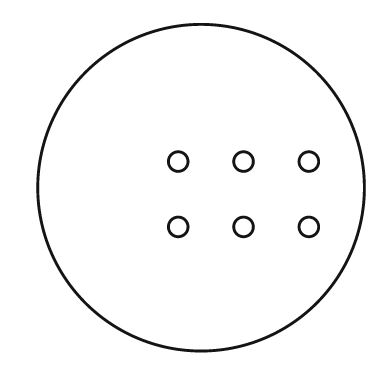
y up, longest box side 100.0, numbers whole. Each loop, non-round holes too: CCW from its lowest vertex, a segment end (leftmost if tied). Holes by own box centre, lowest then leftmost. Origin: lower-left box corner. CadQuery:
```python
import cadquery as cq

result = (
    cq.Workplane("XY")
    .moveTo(50.0, 50.0)
    .circle(50.0)
    .moveTo(43.0, 38.0)
    .circle(3.0)
    .moveTo(63.0, 38.0)
    .circle(3.0)
    .moveTo(83.0, 38.0)
    .circle(3.0)
    .moveTo(43.0, 58.0)
    .circle(3.0)
    .moveTo(63.0, 58.0)
    .circle(3.0)
    .moveTo(83.0, 58.0)
    .circle(3.0)
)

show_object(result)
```